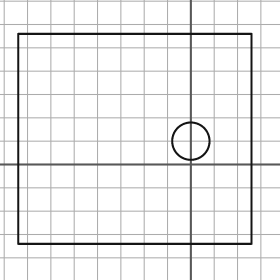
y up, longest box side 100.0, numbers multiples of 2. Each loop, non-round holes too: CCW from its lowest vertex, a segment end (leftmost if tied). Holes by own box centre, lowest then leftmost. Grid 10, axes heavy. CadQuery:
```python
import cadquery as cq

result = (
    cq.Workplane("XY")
    .moveTo(-74.0, -34.0)
    .lineTo(26.0, -34.0)
    .lineTo(26.0, 56.0)
    .lineTo(-74.0, 56.0)
    .close()
    .moveTo(0.0, 10.0)
    .circle(8.0)
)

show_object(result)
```